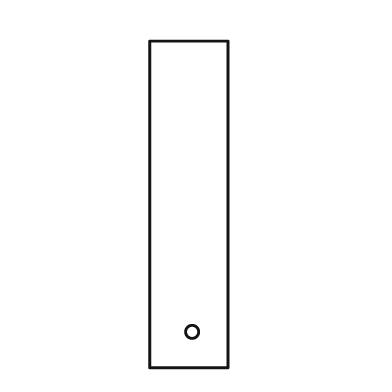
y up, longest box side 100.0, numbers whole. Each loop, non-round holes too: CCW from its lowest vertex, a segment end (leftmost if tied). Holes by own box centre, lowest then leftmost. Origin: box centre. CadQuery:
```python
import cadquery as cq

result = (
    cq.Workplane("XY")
    .moveTo(-12.0, -50.0)
    .lineTo(12.0, -50.0)
    .lineTo(12.0, 50.0)
    .lineTo(-12.0, 50.0)
    .close()
    .moveTo(1.0, -39.0)
    .circle(2.0)
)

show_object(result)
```